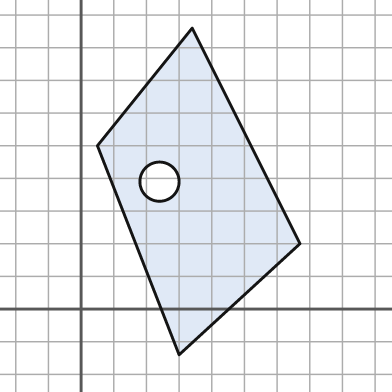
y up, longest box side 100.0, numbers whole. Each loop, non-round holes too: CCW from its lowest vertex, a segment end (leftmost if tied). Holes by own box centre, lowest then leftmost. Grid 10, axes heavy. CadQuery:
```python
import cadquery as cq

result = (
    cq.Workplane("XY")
    .moveTo(30.0, -14.0)
    .lineTo(67.0, 20.0)
    .lineTo(34.0, 86.0)
    .lineTo(5.0, 50.0)
    .close()
    .moveTo(24.0, 39.0)
    .circle(6.0)
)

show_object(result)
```